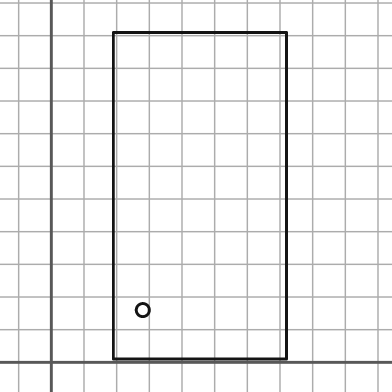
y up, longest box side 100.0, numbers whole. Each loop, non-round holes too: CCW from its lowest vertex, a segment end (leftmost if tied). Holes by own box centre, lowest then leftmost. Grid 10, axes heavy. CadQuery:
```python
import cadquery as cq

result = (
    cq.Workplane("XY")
    .moveTo(19.0, 1.0)
    .lineTo(72.0, 1.0)
    .lineTo(72.0, 101.0)
    .lineTo(19.0, 101.0)
    .close()
    .moveTo(28.0, 16.0)
    .circle(2.0)
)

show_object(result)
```